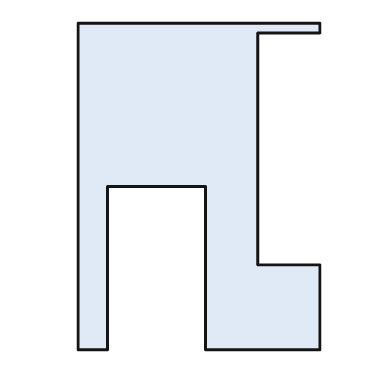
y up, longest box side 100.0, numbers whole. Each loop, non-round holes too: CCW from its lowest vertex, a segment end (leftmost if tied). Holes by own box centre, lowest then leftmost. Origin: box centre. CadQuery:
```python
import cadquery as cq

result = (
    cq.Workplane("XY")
    .moveTo(-37.0, -50.0)
    .lineTo(-28.0, -50.0)
    .lineTo(-28.0, 0.0)
    .lineTo(2.0, 0.0)
    .lineTo(2.0, -50.0)
    .lineTo(37.0, -50.0)
    .lineTo(37.0, -24.0)
    .lineTo(18.0, -24.0)
    .lineTo(18.0, 47.0)
    .lineTo(37.0, 47.0)
    .lineTo(37.0, 50.0)
    .lineTo(-37.0, 50.0)
    .close()
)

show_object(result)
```